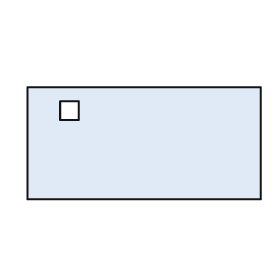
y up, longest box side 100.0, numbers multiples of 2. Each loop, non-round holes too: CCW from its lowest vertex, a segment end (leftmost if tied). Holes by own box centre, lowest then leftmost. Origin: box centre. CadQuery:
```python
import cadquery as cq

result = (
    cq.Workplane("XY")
    .moveTo(-50.0, -24.0)
    .lineTo(50.0, -24.0)
    .lineTo(50.0, 24.0)
    .lineTo(-50.0, 24.0)
    .close()
    .moveTo(-36.0, 10.0)
    .lineTo(-28.0, 10.0)
    .lineTo(-28.0, 18.0)
    .lineTo(-36.0, 18.0)
    .close()
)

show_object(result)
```